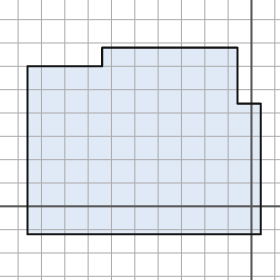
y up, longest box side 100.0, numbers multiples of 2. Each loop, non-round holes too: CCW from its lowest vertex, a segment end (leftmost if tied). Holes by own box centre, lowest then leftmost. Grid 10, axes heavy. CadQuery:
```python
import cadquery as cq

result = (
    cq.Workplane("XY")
    .moveTo(-96.0, -12.0)
    .lineTo(4.0, -12.0)
    .lineTo(4.0, 44.0)
    .lineTo(-6.0, 44.0)
    .lineTo(-6.0, 68.0)
    .lineTo(-64.0, 68.0)
    .lineTo(-64.0, 60.0)
    .lineTo(-96.0, 60.0)
    .close()
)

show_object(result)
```